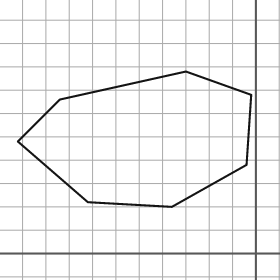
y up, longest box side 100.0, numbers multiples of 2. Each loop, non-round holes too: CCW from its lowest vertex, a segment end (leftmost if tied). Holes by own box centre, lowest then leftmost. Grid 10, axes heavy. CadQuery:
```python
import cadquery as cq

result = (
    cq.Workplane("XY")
    .moveTo(-36.0, 20.0)
    .lineTo(-4.0, 38.0)
    .lineTo(-2.0, 68.0)
    .lineTo(-30.0, 78.0)
    .lineTo(-84.0, 66.0)
    .lineTo(-102.0, 48.0)
    .lineTo(-72.0, 22.0)
    .close()
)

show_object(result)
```